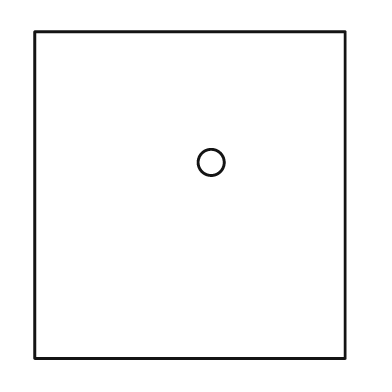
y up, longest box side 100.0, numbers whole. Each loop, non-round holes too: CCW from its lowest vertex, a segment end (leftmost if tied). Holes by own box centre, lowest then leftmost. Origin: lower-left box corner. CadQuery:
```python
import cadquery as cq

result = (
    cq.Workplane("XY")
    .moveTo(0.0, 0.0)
    .lineTo(95.0, 0.0)
    .lineTo(95.0, 100.0)
    .lineTo(0.0, 100.0)
    .close()
    .moveTo(54.0, 60.0)
    .circle(4.0)
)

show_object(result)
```